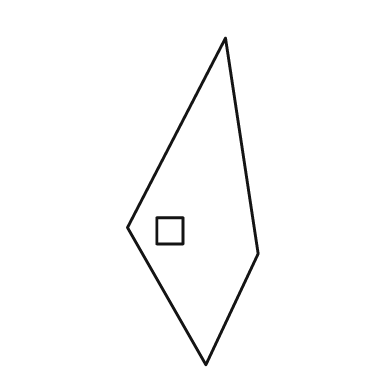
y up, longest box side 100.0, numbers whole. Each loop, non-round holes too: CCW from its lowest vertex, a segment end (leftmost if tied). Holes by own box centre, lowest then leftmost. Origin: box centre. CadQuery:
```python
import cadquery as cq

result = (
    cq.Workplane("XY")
    .moveTo(4.0, -50.0)
    .lineTo(20.0, -16.0)
    .lineTo(10.0, 50.0)
    .lineTo(-20.0, -8.0)
    .close()
    .moveTo(-11.0, -13.0)
    .lineTo(-3.0, -13.0)
    .lineTo(-3.0, -5.0)
    .lineTo(-11.0, -5.0)
    .close()
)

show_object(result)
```